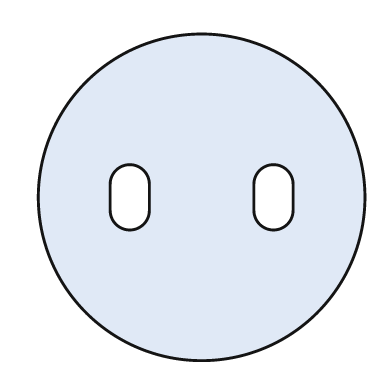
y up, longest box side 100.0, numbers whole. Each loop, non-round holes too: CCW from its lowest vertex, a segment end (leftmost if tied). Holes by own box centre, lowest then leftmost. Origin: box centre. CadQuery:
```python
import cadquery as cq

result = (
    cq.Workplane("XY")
    .moveTo(0.0, 0.0)
    .circle(50.0)
    .moveTo(-28.0, -4.0)
    .threePointArc((-22.0, -10.0), (-16.0, -4.0))
    .lineTo(-16.0, 4.0)
    .threePointArc((-22.0, 10.0), (-28.0, 4.0))
    .close()
    .moveTo(16.0, -4.0)
    .threePointArc((22.0, -10.0), (28.0, -4.0))
    .lineTo(28.0, 4.0)
    .threePointArc((22.0, 10.0), (16.0, 4.0))
    .close()
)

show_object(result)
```